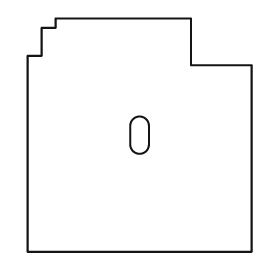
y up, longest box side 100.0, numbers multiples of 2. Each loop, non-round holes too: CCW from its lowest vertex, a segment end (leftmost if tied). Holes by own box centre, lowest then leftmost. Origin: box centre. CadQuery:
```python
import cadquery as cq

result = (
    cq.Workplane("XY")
    .moveTo(-48.0, -50.0)
    .lineTo(48.0, -50.0)
    .lineTo(48.0, 30.0)
    .lineTo(22.0, 30.0)
    .lineTo(22.0, 50.0)
    .lineTo(-36.0, 50.0)
    .lineTo(-36.0, 46.0)
    .lineTo(-42.0, 46.0)
    .lineTo(-42.0, 34.0)
    .lineTo(-48.0, 34.0)
    .close()
    .moveTo(-4.0, -4.0)
    .threePointArc((0.0, -8.0), (4.0, -4.0))
    .lineTo(4.0, 4.0)
    .threePointArc((0.0, 8.0), (-4.0, 4.0))
    .close()
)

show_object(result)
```